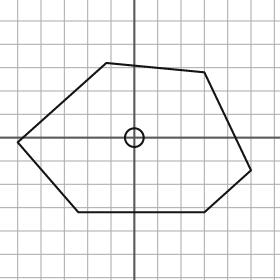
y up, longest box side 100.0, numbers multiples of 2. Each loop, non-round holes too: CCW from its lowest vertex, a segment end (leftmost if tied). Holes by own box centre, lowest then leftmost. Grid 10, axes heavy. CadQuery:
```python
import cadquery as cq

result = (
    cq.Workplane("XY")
    .moveTo(-24.0, -32.0)
    .lineTo(30.0, -32.0)
    .lineTo(50.0, -14.0)
    .lineTo(30.0, 28.0)
    .lineTo(-12.0, 32.0)
    .lineTo(-50.0, -2.0)
    .close()
    .moveTo(0.0, 0.0)
    .circle(4.0)
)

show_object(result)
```